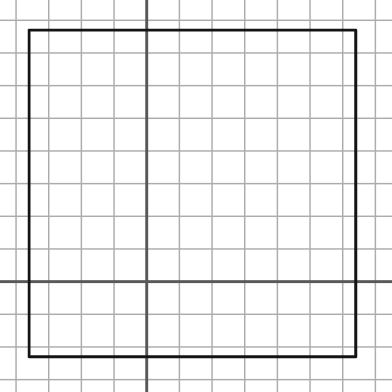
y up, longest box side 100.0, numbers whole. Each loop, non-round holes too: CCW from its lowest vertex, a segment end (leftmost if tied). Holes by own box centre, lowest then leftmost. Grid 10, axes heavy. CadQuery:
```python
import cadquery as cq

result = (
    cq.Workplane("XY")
    .moveTo(-36.0, -23.0)
    .lineTo(64.0, -23.0)
    .lineTo(64.0, 77.0)
    .lineTo(-36.0, 77.0)
    .close()
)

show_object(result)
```